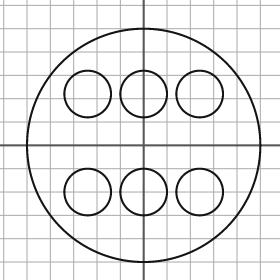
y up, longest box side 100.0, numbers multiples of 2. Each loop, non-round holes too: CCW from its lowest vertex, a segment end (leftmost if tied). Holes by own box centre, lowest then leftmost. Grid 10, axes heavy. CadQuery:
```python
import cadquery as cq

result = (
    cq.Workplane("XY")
    .moveTo(0.0, 0.0)
    .circle(50.0)
    .moveTo(-24.0, -20.0)
    .circle(10.0)
    .moveTo(0.0, -20.0)
    .circle(10.0)
    .moveTo(24.0, -20.0)
    .circle(10.0)
    .moveTo(-24.0, 22.0)
    .circle(10.0)
    .moveTo(0.0, 22.0)
    .circle(10.0)
    .moveTo(24.0, 22.0)
    .circle(10.0)
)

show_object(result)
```